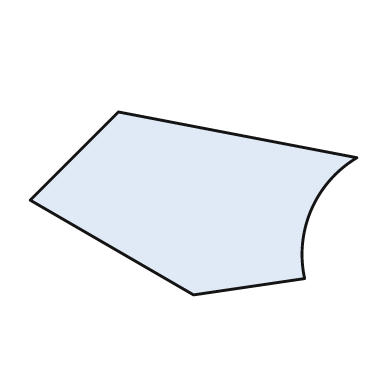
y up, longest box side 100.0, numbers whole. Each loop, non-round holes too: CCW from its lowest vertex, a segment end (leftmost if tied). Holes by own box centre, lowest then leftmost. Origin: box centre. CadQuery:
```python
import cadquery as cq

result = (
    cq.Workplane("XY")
    .moveTo(0.0, -28.0)
    .lineTo(34.0, -23.0)
    .threePointArc((36.0, -2.0), (50.0, 14.0))
    .lineTo(-23.0, 28.0)
    .lineTo(-50.0, 1.0)
    .close()
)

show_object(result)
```